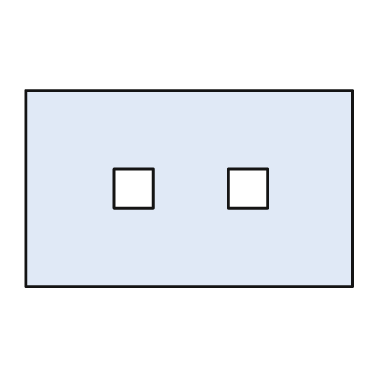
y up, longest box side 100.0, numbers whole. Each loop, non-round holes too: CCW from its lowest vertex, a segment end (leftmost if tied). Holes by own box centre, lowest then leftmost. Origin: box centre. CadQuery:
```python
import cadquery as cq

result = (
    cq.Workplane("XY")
    .moveTo(-50.0, -30.0)
    .lineTo(50.0, -30.0)
    .lineTo(50.0, 30.0)
    .lineTo(-50.0, 30.0)
    .close()
    .moveTo(-23.0, -6.0)
    .lineTo(-11.0, -6.0)
    .lineTo(-11.0, 6.0)
    .lineTo(-23.0, 6.0)
    .close()
    .moveTo(12.0, -6.0)
    .lineTo(24.0, -6.0)
    .lineTo(24.0, 6.0)
    .lineTo(12.0, 6.0)
    .close()
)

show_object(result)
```